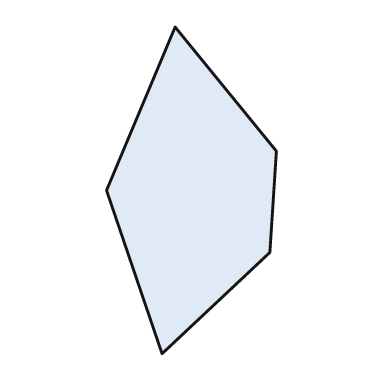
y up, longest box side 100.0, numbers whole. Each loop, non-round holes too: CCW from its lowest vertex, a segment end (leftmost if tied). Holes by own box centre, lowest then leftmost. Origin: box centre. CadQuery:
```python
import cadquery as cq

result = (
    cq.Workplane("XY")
    .moveTo(-9.0, -50.0)
    .lineTo(24.0, -19.0)
    .lineTo(26.0, 12.0)
    .lineTo(-5.0, 50.0)
    .lineTo(-26.0, 0.0)
    .close()
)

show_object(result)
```